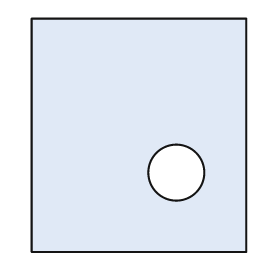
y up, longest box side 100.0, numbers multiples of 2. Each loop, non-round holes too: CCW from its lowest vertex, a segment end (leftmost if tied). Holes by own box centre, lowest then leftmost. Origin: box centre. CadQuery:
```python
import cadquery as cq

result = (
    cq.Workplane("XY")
    .moveTo(-46.0, -50.0)
    .lineTo(46.0, -50.0)
    .lineTo(46.0, 50.0)
    .lineTo(-46.0, 50.0)
    .close()
    .moveTo(16.0, -16.0)
    .circle(12.0)
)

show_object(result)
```